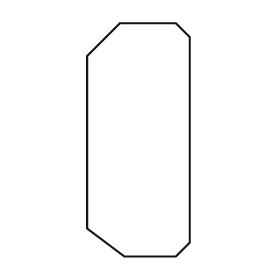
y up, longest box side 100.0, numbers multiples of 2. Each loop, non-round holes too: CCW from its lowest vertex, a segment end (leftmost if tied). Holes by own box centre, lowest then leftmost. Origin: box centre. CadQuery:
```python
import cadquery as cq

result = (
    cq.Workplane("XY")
    .moveTo(-6.0, -50.0)
    .lineTo(16.0, -50.0)
    .lineTo(22.0, -44.0)
    .lineTo(22.0, 44.0)
    .lineTo(16.0, 50.0)
    .lineTo(-8.0, 50.0)
    .lineTo(-22.0, 36.0)
    .lineTo(-22.0, -38.0)
    .close()
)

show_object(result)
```